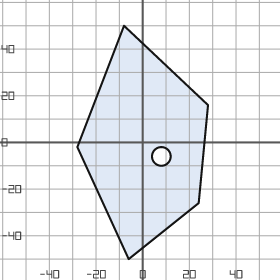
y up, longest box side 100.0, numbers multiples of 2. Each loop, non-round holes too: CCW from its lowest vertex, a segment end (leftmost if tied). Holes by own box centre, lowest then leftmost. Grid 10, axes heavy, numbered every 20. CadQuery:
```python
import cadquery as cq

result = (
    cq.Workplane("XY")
    .moveTo(-6.0, -50.0)
    .lineTo(24.0, -26.0)
    .lineTo(28.0, 16.0)
    .lineTo(-8.0, 50.0)
    .lineTo(-28.0, -2.0)
    .close()
    .moveTo(8.0, -6.0)
    .circle(4.0)
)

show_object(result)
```